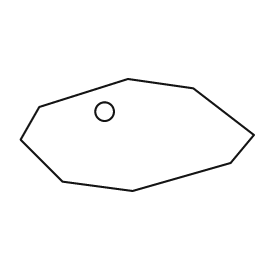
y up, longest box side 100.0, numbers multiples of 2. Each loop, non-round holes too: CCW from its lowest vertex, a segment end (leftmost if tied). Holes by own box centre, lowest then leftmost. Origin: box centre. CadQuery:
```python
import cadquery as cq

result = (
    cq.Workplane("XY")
    .moveTo(-2.0, -24.0)
    .lineTo(40.0, -12.0)
    .lineTo(50.0, 0.0)
    .lineTo(24.0, 20.0)
    .lineTo(-4.0, 24.0)
    .lineTo(-42.0, 12.0)
    .lineTo(-50.0, -2.0)
    .lineTo(-32.0, -20.0)
    .close()
    .moveTo(-14.0, 10.0)
    .circle(4.0)
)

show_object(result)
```